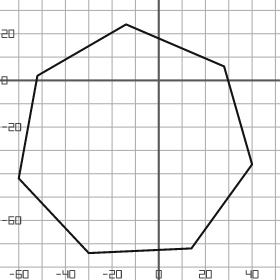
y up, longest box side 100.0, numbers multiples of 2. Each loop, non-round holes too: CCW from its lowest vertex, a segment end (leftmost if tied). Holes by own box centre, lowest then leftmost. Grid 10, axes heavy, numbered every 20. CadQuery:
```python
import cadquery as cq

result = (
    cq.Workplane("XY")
    .moveTo(-30.0, -74.0)
    .lineTo(14.0, -72.0)
    .lineTo(40.0, -36.0)
    .lineTo(28.0, 6.0)
    .lineTo(-14.0, 24.0)
    .lineTo(-52.0, 2.0)
    .lineTo(-60.0, -42.0)
    .close()
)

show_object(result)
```